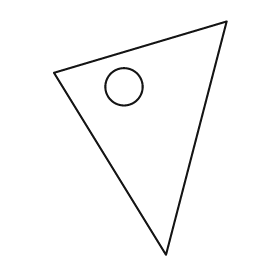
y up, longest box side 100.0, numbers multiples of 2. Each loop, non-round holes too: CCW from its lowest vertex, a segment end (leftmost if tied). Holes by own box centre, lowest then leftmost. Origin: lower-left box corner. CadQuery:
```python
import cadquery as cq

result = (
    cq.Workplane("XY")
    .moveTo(48.0, 0.0)
    .lineTo(74.0, 100.0)
    .lineTo(0.0, 78.0)
    .close()
    .moveTo(30.0, 72.0)
    .circle(8.0)
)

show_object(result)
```